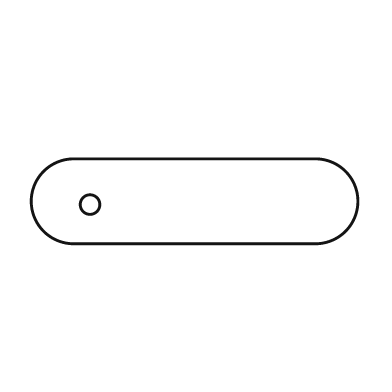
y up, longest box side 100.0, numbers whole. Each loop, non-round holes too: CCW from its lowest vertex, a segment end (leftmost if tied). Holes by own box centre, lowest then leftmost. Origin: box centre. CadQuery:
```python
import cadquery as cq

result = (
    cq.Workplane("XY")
    .moveTo(-37.0, -13.0)
    .lineTo(37.0, -13.0)
    .threePointArc((50.0, 0.0), (37.0, 13.0))
    .lineTo(-37.0, 13.0)
    .threePointArc((-50.0, 0.0), (-37.0, -13.0))
    .close()
    .moveTo(-32.0, -1.0)
    .circle(3.0)
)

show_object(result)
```